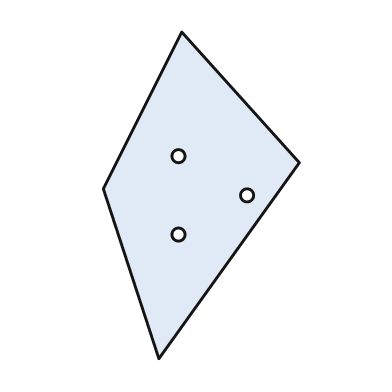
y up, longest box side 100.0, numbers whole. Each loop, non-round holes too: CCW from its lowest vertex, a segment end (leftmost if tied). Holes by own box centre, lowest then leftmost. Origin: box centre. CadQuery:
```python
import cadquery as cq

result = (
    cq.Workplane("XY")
    .moveTo(-13.0, -50.0)
    .lineTo(30.0, 10.0)
    .lineTo(-6.0, 50.0)
    .lineTo(-30.0, 2.0)
    .close()
    .moveTo(-7.0, -12.0)
    .circle(2.0)
    .moveTo(14.0, 0.0)
    .circle(2.0)
    .moveTo(-7.0, 12.0)
    .circle(2.0)
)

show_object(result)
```